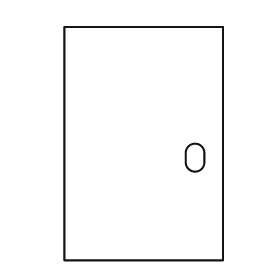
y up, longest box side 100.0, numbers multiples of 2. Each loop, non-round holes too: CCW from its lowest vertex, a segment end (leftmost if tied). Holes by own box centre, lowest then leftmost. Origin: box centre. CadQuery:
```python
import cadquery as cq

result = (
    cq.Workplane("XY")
    .moveTo(-34.0, -50.0)
    .lineTo(34.0, -50.0)
    .lineTo(34.0, 50.0)
    .lineTo(-34.0, 50.0)
    .close()
    .moveTo(18.0, -8.0)
    .threePointArc((22.0, -12.0), (26.0, -8.0))
    .lineTo(26.0, -4.0)
    .threePointArc((22.0, 0.0), (18.0, -4.0))
    .close()
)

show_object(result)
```